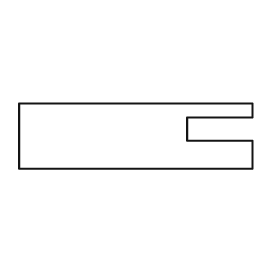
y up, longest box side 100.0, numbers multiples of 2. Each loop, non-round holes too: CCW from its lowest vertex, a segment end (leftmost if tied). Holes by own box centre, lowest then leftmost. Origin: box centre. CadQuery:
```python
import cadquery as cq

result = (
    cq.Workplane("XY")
    .moveTo(-50.0, -14.0)
    .lineTo(50.0, -14.0)
    .lineTo(50.0, -2.0)
    .lineTo(22.0, -2.0)
    .lineTo(22.0, 8.0)
    .lineTo(50.0, 8.0)
    .lineTo(50.0, 14.0)
    .lineTo(-50.0, 14.0)
    .close()
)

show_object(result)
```